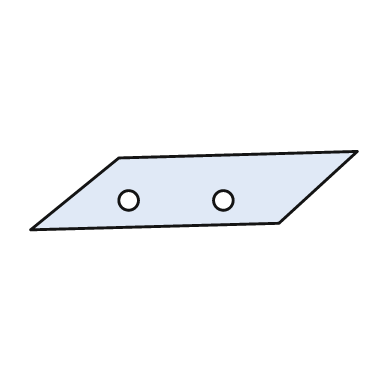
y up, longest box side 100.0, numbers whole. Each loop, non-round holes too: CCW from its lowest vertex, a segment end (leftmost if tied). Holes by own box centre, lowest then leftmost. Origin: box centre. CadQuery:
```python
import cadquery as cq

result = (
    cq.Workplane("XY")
    .moveTo(-50.0, -12.0)
    .lineTo(26.0, -10.0)
    .lineTo(50.0, 12.0)
    .lineTo(-23.0, 10.0)
    .close()
    .moveTo(-20.0, -3.0)
    .circle(3.0)
    .moveTo(9.0, -3.0)
    .circle(3.0)
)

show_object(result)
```